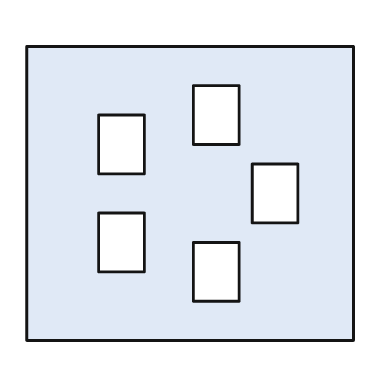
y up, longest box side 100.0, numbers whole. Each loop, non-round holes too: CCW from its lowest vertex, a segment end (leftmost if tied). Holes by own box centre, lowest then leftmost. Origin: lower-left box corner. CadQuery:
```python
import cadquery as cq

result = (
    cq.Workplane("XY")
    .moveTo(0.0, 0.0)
    .lineTo(100.0, 0.0)
    .lineTo(100.0, 90.0)
    .lineTo(0.0, 90.0)
    .close()
    .moveTo(51.0, 12.0)
    .lineTo(65.0, 12.0)
    .lineTo(65.0, 30.0)
    .lineTo(51.0, 30.0)
    .close()
    .moveTo(22.0, 21.0)
    .lineTo(36.0, 21.0)
    .lineTo(36.0, 39.0)
    .lineTo(22.0, 39.0)
    .close()
    .moveTo(69.0, 36.0)
    .lineTo(83.0, 36.0)
    .lineTo(83.0, 54.0)
    .lineTo(69.0, 54.0)
    .close()
    .moveTo(22.0, 51.0)
    .lineTo(36.0, 51.0)
    .lineTo(36.0, 69.0)
    .lineTo(22.0, 69.0)
    .close()
    .moveTo(51.0, 60.0)
    .lineTo(65.0, 60.0)
    .lineTo(65.0, 78.0)
    .lineTo(51.0, 78.0)
    .close()
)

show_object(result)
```